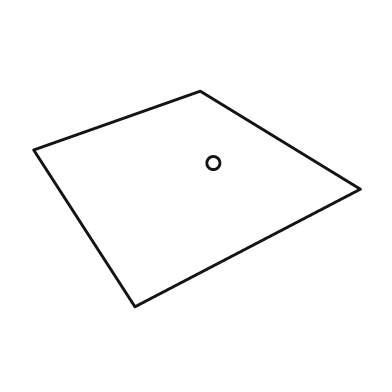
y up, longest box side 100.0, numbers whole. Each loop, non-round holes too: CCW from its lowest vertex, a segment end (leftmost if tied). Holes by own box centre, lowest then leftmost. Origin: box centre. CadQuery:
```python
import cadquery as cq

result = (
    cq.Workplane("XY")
    .moveTo(-19.0, -33.0)
    .lineTo(50.0, 3.0)
    .lineTo(1.0, 33.0)
    .lineTo(-50.0, 15.0)
    .close()
    .moveTo(5.0, 11.0)
    .circle(2.0)
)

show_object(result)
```